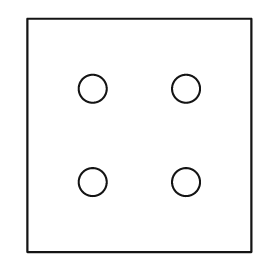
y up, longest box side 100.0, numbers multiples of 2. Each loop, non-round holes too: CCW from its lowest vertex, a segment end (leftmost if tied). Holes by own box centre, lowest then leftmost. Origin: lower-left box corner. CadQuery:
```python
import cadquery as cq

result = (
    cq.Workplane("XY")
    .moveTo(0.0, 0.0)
    .lineTo(96.0, 0.0)
    .lineTo(96.0, 100.0)
    .lineTo(0.0, 100.0)
    .close()
    .moveTo(28.0, 30.0)
    .circle(6.0)
    .moveTo(68.0, 30.0)
    .circle(6.0)
    .moveTo(28.0, 70.0)
    .circle(6.0)
    .moveTo(68.0, 70.0)
    .circle(6.0)
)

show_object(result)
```